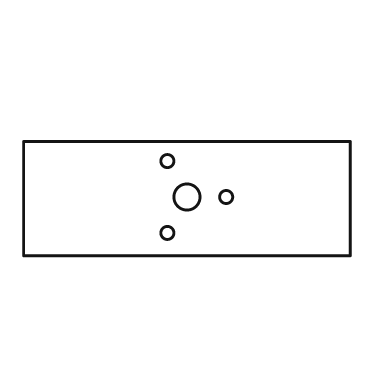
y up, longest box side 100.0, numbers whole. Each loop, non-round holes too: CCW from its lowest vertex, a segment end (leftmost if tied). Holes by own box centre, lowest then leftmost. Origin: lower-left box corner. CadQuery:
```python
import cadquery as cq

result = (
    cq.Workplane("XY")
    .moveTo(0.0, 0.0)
    .lineTo(100.0, 0.0)
    .lineTo(100.0, 35.0)
    .lineTo(0.0, 35.0)
    .close()
    .moveTo(44.0, 7.0)
    .circle(2.0)
    .moveTo(50.0, 18.0)
    .circle(4.0)
    .moveTo(62.0, 18.0)
    .circle(2.0)
    .moveTo(44.0, 29.0)
    .circle(2.0)
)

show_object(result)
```